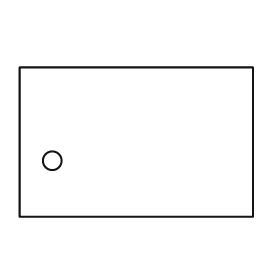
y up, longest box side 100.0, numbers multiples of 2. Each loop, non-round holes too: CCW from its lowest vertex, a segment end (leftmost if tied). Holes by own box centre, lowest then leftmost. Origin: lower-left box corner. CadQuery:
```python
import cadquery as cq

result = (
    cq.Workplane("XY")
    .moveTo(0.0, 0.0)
    .lineTo(100.0, 0.0)
    .lineTo(100.0, 64.0)
    .lineTo(0.0, 64.0)
    .close()
    .moveTo(14.0, 24.0)
    .circle(4.0)
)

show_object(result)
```